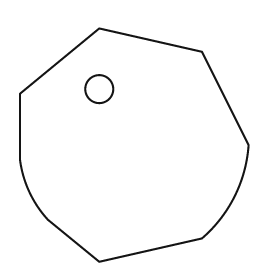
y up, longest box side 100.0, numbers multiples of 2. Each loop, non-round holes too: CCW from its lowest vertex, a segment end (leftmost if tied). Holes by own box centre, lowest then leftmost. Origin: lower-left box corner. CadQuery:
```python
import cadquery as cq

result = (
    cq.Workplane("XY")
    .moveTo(34.0, 0.0)
    .lineTo(78.0, 10.0)
    .threePointArc((92.0, 28.0), (98.0, 50.0))
    .lineTo(78.0, 90.0)
    .lineTo(34.0, 100.0)
    .lineTo(0.0, 72.0)
    .lineTo(0.0, 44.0)
    .threePointArc((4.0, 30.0), (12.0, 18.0))
    .close()
    .moveTo(34.0, 74.0)
    .circle(6.0)
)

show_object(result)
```